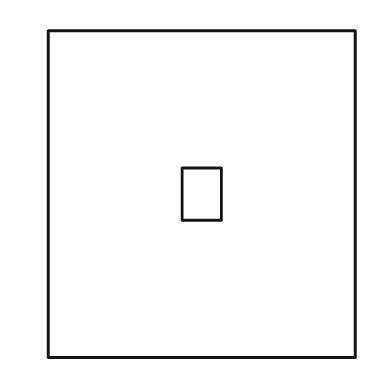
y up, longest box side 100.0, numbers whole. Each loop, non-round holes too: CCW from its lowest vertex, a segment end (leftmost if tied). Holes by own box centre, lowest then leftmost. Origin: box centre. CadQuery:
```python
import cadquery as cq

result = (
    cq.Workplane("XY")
    .moveTo(-47.0, -50.0)
    .lineTo(47.0, -50.0)
    .lineTo(47.0, 50.0)
    .lineTo(-47.0, 50.0)
    .close()
    .moveTo(-6.0, -8.0)
    .lineTo(6.0, -8.0)
    .lineTo(6.0, 8.0)
    .lineTo(-6.0, 8.0)
    .close()
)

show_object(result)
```